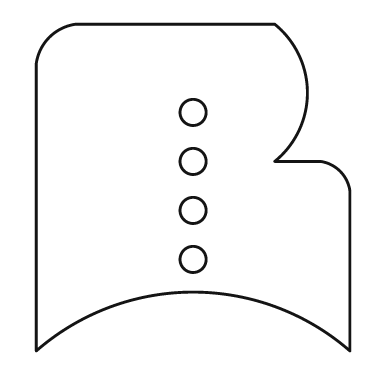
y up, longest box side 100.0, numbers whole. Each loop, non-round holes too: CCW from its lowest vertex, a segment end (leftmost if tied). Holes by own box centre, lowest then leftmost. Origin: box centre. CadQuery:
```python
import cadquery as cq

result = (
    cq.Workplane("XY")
    .moveTo(-48.0, -50.0)
    .threePointArc((0.0, -32.0), (48.0, -50.0))
    .lineTo(48.0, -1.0)
    .threePointArc((45.0, 5.0), (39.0, 8.0))
    .lineTo(25.0, 8.0)
    .threePointArc((35.0, 29.0), (25.0, 50.0))
    .lineTo(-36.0, 50.0)
    .threePointArc((-44.0, 46.0), (-48.0, 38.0))
    .close()
    .moveTo(0.0, -22.0)
    .circle(4.0)
    .moveTo(0.0, -7.0)
    .circle(4.0)
    .moveTo(0.0, 8.0)
    .circle(4.0)
    .moveTo(0.0, 23.0)
    .circle(4.0)
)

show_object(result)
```